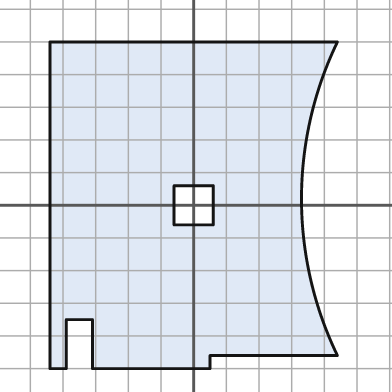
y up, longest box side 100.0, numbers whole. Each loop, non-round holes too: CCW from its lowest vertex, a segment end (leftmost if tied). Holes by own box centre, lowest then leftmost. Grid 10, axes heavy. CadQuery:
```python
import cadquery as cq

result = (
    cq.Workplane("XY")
    .moveTo(-44.0, -50.0)
    .lineTo(-39.0, -50.0)
    .lineTo(-39.0, -35.0)
    .lineTo(-31.0, -35.0)
    .lineTo(-31.0, -50.0)
    .lineTo(5.0, -50.0)
    .lineTo(5.0, -46.0)
    .lineTo(44.0, -46.0)
    .threePointArc((33.0, 2.0), (44.0, 50.0))
    .lineTo(-44.0, 50.0)
    .close()
    .moveTo(-6.0, -6.0)
    .lineTo(6.0, -6.0)
    .lineTo(6.0, 6.0)
    .lineTo(-6.0, 6.0)
    .close()
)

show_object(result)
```